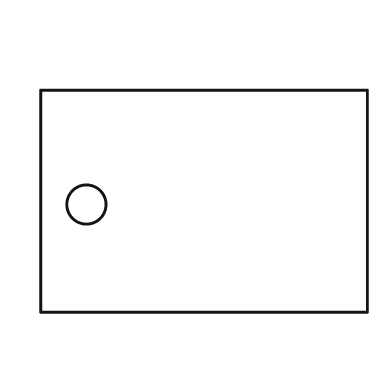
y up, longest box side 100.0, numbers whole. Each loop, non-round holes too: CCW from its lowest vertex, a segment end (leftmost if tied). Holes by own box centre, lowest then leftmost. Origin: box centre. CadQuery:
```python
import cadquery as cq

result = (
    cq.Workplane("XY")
    .moveTo(-50.0, -34.0)
    .lineTo(50.0, -34.0)
    .lineTo(50.0, 34.0)
    .lineTo(-50.0, 34.0)
    .close()
    .moveTo(-36.0, -1.0)
    .circle(6.0)
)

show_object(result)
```